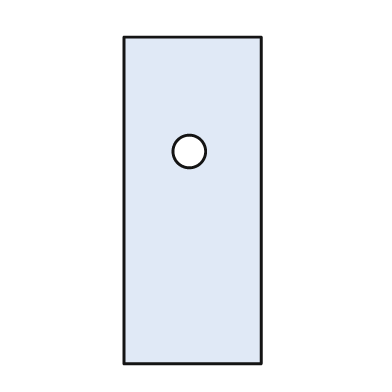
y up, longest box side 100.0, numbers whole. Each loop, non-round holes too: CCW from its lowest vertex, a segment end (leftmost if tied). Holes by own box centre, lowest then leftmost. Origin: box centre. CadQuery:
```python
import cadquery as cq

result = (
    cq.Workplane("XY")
    .moveTo(-21.0, -50.0)
    .lineTo(21.0, -50.0)
    .lineTo(21.0, 50.0)
    .lineTo(-21.0, 50.0)
    .close()
    .moveTo(-1.0, 15.0)
    .circle(5.0)
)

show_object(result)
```